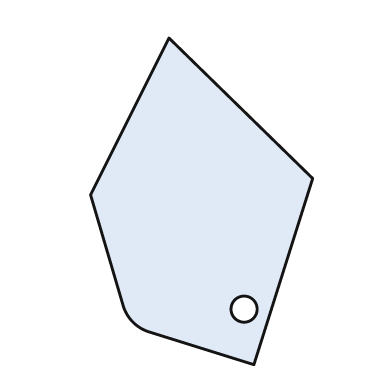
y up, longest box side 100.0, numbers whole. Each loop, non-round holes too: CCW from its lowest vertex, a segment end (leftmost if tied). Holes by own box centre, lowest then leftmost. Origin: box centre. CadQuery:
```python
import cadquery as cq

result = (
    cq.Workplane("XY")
    .moveTo(16.0, -50.0)
    .lineTo(34.0, 7.0)
    .lineTo(-10.0, 50.0)
    .lineTo(-34.0, 2.0)
    .lineTo(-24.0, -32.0)
    .threePointArc((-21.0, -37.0), (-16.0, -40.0))
    .close()
    .moveTo(13.0, -33.0)
    .circle(4.0)
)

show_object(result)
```